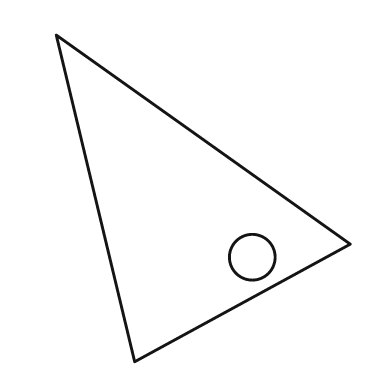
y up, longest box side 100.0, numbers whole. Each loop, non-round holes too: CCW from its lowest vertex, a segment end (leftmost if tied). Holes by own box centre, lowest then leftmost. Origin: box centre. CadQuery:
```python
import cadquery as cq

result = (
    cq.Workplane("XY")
    .moveTo(-21.0, -50.0)
    .lineTo(45.0, -14.0)
    .lineTo(-45.0, 50.0)
    .close()
    .moveTo(15.0, -18.0)
    .circle(7.0)
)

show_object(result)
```